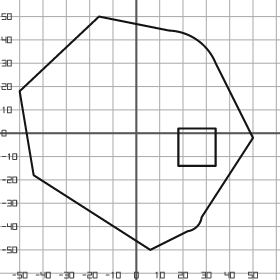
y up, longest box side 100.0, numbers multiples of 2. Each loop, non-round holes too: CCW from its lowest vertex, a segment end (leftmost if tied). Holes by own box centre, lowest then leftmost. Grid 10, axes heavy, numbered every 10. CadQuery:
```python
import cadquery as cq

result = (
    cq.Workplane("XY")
    .moveTo(6.0, -50.0)
    .lineTo(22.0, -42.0)
    .threePointArc((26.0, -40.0), (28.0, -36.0))
    .lineTo(50.0, -2.0)
    .lineTo(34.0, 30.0)
    .threePointArc((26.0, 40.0), (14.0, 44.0))
    .lineTo(-16.0, 50.0)
    .lineTo(-50.0, 18.0)
    .lineTo(-44.0, -18.0)
    .close()
    .moveTo(18.0, -14.0)
    .lineTo(34.0, -14.0)
    .lineTo(34.0, 2.0)
    .lineTo(18.0, 2.0)
    .close()
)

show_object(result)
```